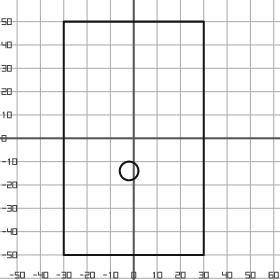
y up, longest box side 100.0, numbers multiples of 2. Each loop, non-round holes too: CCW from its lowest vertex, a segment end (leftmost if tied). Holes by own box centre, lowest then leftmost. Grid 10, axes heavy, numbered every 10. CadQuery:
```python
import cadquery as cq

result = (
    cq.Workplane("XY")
    .moveTo(-30.0, -50.0)
    .lineTo(30.0, -50.0)
    .lineTo(30.0, 50.0)
    .lineTo(-30.0, 50.0)
    .close()
    .moveTo(-2.0, -14.0)
    .circle(4.0)
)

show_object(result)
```